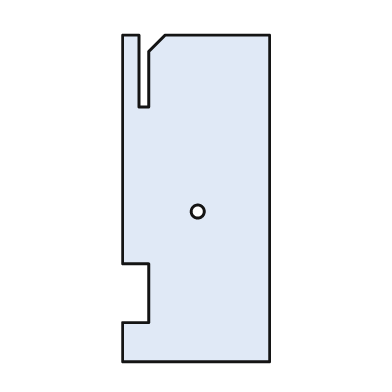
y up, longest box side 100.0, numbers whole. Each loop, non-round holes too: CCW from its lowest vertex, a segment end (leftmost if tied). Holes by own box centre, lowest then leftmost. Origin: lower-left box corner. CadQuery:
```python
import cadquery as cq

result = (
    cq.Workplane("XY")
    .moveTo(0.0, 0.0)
    .lineTo(45.0, 0.0)
    .lineTo(45.0, 100.0)
    .lineTo(13.0, 100.0)
    .lineTo(8.0, 95.0)
    .lineTo(8.0, 78.0)
    .lineTo(5.0, 78.0)
    .lineTo(5.0, 100.0)
    .lineTo(0.0, 100.0)
    .lineTo(0.0, 30.0)
    .lineTo(8.0, 30.0)
    .lineTo(8.0, 12.0)
    .lineTo(0.0, 12.0)
    .close()
    .moveTo(23.0, 46.0)
    .circle(2.0)
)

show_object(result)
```